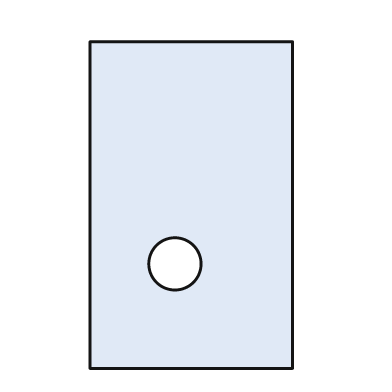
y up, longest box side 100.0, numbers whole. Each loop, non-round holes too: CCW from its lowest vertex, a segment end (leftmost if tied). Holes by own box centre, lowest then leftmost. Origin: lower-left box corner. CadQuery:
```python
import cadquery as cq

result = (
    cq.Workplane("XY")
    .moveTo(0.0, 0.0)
    .lineTo(62.0, 0.0)
    .lineTo(62.0, 100.0)
    .lineTo(0.0, 100.0)
    .close()
    .moveTo(26.0, 32.0)
    .circle(8.0)
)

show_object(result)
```